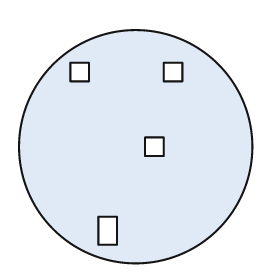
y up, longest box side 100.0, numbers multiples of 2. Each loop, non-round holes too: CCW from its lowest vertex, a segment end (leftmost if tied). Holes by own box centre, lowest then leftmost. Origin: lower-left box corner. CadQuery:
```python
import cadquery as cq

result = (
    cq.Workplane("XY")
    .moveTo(50.0, 50.0)
    .circle(50.0)
    .moveTo(34.0, 8.0)
    .lineTo(42.0, 8.0)
    .lineTo(42.0, 20.0)
    .lineTo(34.0, 20.0)
    .close()
    .moveTo(54.0, 46.0)
    .lineTo(62.0, 46.0)
    .lineTo(62.0, 54.0)
    .lineTo(54.0, 54.0)
    .close()
    .moveTo(22.0, 78.0)
    .lineTo(30.0, 78.0)
    .lineTo(30.0, 86.0)
    .lineTo(22.0, 86.0)
    .close()
    .moveTo(62.0, 78.0)
    .lineTo(70.0, 78.0)
    .lineTo(70.0, 86.0)
    .lineTo(62.0, 86.0)
    .close()
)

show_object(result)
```